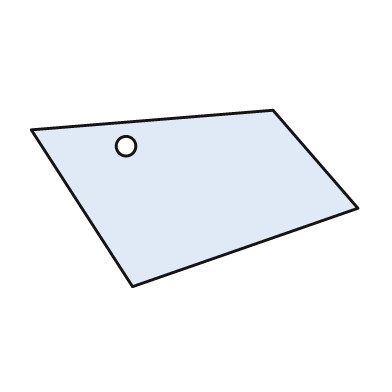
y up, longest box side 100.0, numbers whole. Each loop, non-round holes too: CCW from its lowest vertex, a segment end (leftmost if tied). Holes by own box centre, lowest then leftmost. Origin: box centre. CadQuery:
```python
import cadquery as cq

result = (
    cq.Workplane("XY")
    .moveTo(-19.0, -27.0)
    .lineTo(50.0, -3.0)
    .lineTo(24.0, 27.0)
    .lineTo(-50.0, 21.0)
    .close()
    .moveTo(-21.0, 16.0)
    .circle(3.0)
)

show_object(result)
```